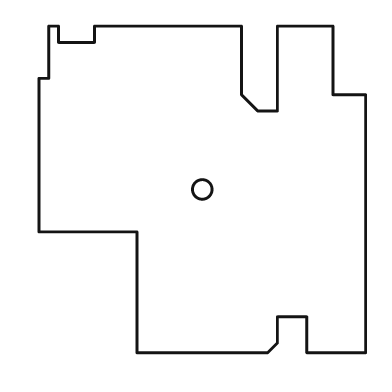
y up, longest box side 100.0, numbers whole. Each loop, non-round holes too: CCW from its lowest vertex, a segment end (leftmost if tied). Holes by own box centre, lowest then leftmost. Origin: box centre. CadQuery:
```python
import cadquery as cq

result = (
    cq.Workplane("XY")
    .moveTo(-20.0, -50.0)
    .lineTo(20.0, -50.0)
    .lineTo(23.0, -47.0)
    .lineTo(23.0, -39.0)
    .lineTo(32.0, -39.0)
    .lineTo(32.0, -50.0)
    .lineTo(50.0, -50.0)
    .lineTo(50.0, 29.0)
    .lineTo(40.0, 29.0)
    .lineTo(40.0, 50.0)
    .lineTo(23.0, 50.0)
    .lineTo(23.0, 24.0)
    .lineTo(17.0, 24.0)
    .lineTo(12.0, 29.0)
    .lineTo(12.0, 50.0)
    .lineTo(-33.0, 50.0)
    .lineTo(-33.0, 45.0)
    .lineTo(-44.0, 45.0)
    .lineTo(-44.0, 50.0)
    .lineTo(-47.0, 50.0)
    .lineTo(-47.0, 34.0)
    .lineTo(-50.0, 34.0)
    .lineTo(-50.0, -13.0)
    .lineTo(-20.0, -13.0)
    .close()
    .moveTo(0.0, 0.0)
    .circle(3.0)
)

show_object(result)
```